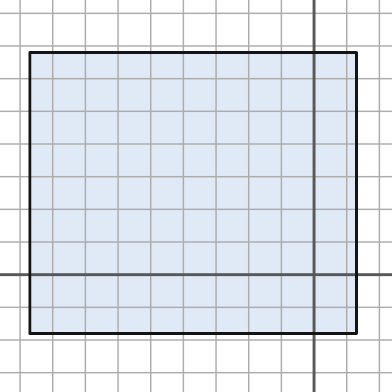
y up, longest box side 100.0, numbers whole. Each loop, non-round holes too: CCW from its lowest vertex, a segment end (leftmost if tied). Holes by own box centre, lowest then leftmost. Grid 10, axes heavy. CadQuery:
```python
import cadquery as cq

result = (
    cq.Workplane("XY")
    .moveTo(-87.0, -18.0)
    .lineTo(13.0, -18.0)
    .lineTo(13.0, 68.0)
    .lineTo(-87.0, 68.0)
    .close()
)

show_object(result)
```